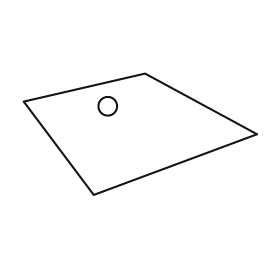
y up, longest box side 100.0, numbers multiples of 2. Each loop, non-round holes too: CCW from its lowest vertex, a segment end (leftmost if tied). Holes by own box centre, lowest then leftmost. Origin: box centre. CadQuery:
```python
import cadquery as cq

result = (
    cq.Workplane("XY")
    .moveTo(-20.0, -26.0)
    .lineTo(50.0, 0.0)
    .lineTo(2.0, 26.0)
    .lineTo(-50.0, 14.0)
    .close()
    .moveTo(-14.0, 12.0)
    .circle(4.0)
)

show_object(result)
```